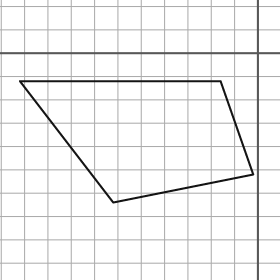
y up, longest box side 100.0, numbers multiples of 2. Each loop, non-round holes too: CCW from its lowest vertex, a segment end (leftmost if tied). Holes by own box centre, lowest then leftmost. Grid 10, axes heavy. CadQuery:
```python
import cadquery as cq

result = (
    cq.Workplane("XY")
    .moveTo(-62.0, -64.0)
    .lineTo(-2.0, -52.0)
    .lineTo(-16.0, -12.0)
    .lineTo(-102.0, -12.0)
    .close()
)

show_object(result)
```